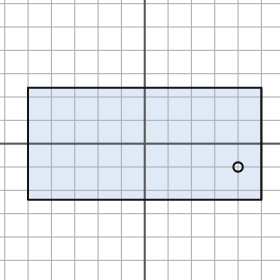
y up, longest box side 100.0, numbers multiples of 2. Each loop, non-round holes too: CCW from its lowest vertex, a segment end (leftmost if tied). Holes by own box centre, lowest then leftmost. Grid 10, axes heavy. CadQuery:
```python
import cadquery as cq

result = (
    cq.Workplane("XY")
    .moveTo(-50.0, -24.0)
    .lineTo(50.0, -24.0)
    .lineTo(50.0, 24.0)
    .lineTo(-50.0, 24.0)
    .close()
    .moveTo(40.0, -10.0)
    .circle(2.0)
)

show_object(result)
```